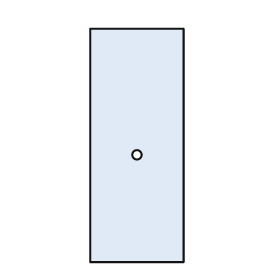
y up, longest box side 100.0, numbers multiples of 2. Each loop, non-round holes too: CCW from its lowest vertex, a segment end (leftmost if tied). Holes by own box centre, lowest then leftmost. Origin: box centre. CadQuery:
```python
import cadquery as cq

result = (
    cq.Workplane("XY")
    .moveTo(-20.0, -50.0)
    .lineTo(20.0, -50.0)
    .lineTo(20.0, 50.0)
    .lineTo(-20.0, 50.0)
    .close()
    .moveTo(0.0, -4.0)
    .circle(2.0)
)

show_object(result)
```